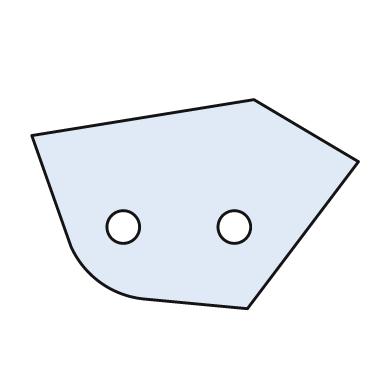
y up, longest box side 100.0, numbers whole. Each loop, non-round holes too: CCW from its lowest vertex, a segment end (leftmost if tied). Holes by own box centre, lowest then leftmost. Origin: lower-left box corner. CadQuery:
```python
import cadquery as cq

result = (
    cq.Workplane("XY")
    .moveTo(66.0, 0.0)
    .lineTo(100.0, 45.0)
    .lineTo(68.0, 64.0)
    .lineTo(0.0, 53.0)
    .lineTo(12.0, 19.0)
    .threePointArc((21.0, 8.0), (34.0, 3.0))
    .close()
    .moveTo(28.0, 25.0)
    .circle(5.0)
    .moveTo(62.0, 25.0)
    .circle(5.0)
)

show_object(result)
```